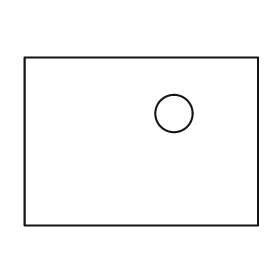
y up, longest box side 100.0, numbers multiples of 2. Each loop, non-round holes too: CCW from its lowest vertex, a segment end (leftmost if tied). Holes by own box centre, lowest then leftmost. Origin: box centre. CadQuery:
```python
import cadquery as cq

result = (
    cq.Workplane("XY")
    .moveTo(-50.0, -36.0)
    .lineTo(50.0, -36.0)
    .lineTo(50.0, 36.0)
    .lineTo(-50.0, 36.0)
    .close()
    .moveTo(14.0, 12.0)
    .circle(8.0)
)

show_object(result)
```